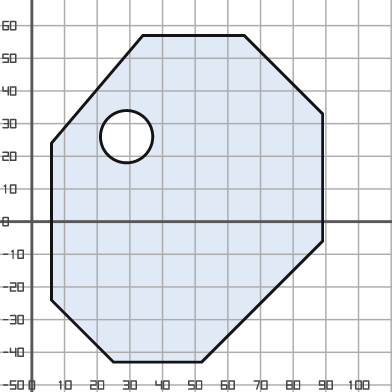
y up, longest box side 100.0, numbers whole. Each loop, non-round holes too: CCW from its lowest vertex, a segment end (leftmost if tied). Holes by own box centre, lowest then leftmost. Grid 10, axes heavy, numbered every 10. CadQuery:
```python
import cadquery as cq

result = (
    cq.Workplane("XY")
    .moveTo(25.0, -43.0)
    .lineTo(52.0, -43.0)
    .lineTo(89.0, -6.0)
    .lineTo(89.0, 33.0)
    .lineTo(65.0, 57.0)
    .lineTo(34.0, 57.0)
    .lineTo(6.0, 24.0)
    .lineTo(6.0, -24.0)
    .close()
    .moveTo(29.0, 26.0)
    .circle(8.0)
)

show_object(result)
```